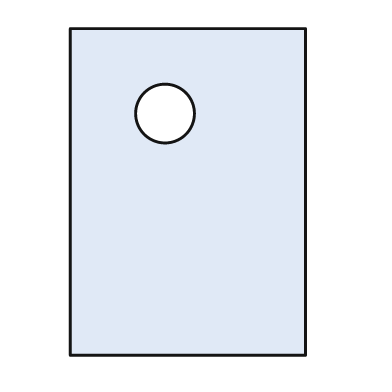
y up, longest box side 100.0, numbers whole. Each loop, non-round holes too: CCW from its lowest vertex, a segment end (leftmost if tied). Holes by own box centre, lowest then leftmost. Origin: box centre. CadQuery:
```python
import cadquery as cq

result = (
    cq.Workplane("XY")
    .moveTo(-36.0, -50.0)
    .lineTo(36.0, -50.0)
    .lineTo(36.0, 50.0)
    .lineTo(-36.0, 50.0)
    .close()
    .moveTo(-7.0, 24.0)
    .circle(9.0)
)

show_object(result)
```